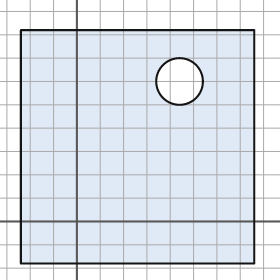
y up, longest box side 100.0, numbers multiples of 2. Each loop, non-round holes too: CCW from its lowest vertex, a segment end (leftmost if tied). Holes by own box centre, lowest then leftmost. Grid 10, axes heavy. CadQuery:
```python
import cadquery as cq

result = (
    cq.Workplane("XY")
    .moveTo(-24.0, -18.0)
    .lineTo(76.0, -18.0)
    .lineTo(76.0, 82.0)
    .lineTo(-24.0, 82.0)
    .close()
    .moveTo(44.0, 60.0)
    .circle(10.0)
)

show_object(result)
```